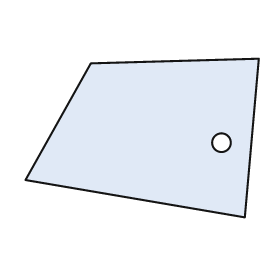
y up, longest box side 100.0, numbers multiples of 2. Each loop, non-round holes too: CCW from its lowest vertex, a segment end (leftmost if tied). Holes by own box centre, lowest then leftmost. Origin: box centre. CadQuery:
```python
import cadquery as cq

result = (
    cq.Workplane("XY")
    .moveTo(44.0, -34.0)
    .lineTo(50.0, 34.0)
    .lineTo(-22.0, 32.0)
    .lineTo(-50.0, -18.0)
    .close()
    .moveTo(34.0, -2.0)
    .circle(4.0)
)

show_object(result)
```